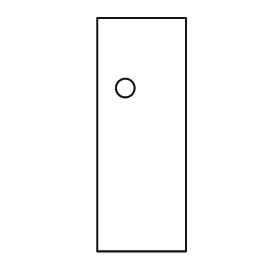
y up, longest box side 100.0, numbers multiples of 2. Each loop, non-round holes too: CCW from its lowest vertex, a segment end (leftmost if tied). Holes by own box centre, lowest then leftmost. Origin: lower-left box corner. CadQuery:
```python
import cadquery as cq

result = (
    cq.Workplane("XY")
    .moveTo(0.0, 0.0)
    .lineTo(38.0, 0.0)
    .lineTo(38.0, 100.0)
    .lineTo(0.0, 100.0)
    .close()
    .moveTo(12.0, 70.0)
    .circle(4.0)
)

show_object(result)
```